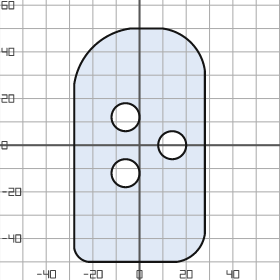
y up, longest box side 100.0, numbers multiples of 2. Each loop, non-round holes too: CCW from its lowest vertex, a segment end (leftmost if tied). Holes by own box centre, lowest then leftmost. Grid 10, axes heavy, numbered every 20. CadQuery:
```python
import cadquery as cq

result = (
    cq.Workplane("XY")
    .moveTo(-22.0, -50.0)
    .lineTo(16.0, -50.0)
    .threePointArc((24.0, -46.0), (28.0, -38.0))
    .lineTo(28.0, 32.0)
    .threePointArc((22.0, 44.0), (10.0, 50.0))
    .lineTo(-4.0, 50.0)
    .threePointArc((-20.0, 42.0), (-28.0, 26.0))
    .lineTo(-28.0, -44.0)
    .threePointArc((-26.0, -48.0), (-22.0, -50.0))
    .close()
    .moveTo(-6.0, -12.0)
    .circle(6.0)
    .moveTo(14.0, 0.0)
    .circle(6.0)
    .moveTo(-6.0, 12.0)
    .circle(6.0)
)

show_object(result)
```